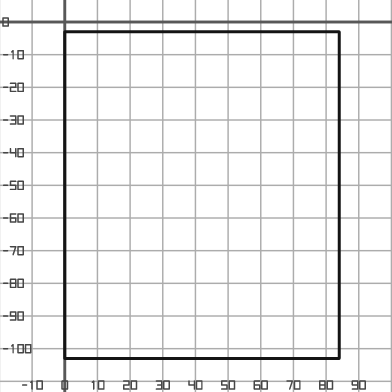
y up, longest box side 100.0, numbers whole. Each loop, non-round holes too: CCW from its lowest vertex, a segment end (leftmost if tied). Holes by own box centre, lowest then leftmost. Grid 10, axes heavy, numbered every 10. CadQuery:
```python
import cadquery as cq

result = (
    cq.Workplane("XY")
    .moveTo(0.0, -103.0)
    .lineTo(84.0, -103.0)
    .lineTo(84.0, -3.0)
    .lineTo(0.0, -3.0)
    .close()
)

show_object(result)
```